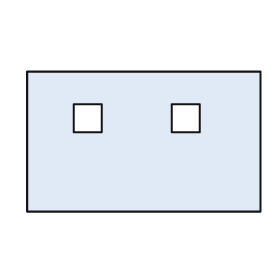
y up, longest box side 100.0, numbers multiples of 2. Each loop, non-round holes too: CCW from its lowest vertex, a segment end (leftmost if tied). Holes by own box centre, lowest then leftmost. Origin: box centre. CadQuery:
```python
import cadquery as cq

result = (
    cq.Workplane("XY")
    .moveTo(-50.0, -30.0)
    .lineTo(50.0, -30.0)
    .lineTo(50.0, 30.0)
    .lineTo(-50.0, 30.0)
    .close()
    .moveTo(-30.0, 4.0)
    .lineTo(-18.0, 4.0)
    .lineTo(-18.0, 16.0)
    .lineTo(-30.0, 16.0)
    .close()
    .moveTo(12.0, 4.0)
    .lineTo(24.0, 4.0)
    .lineTo(24.0, 16.0)
    .lineTo(12.0, 16.0)
    .close()
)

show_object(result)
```